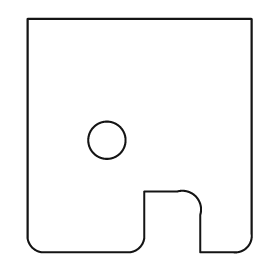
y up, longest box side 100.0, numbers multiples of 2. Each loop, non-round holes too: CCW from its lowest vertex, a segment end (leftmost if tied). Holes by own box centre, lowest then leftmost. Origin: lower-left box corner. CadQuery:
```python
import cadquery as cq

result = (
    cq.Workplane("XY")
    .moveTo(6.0, 0.0)
    .lineTo(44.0, 0.0)
    .threePointArc((48.0, 2.0), (50.0, 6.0))
    .lineTo(50.0, 26.0)
    .lineTo(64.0, 26.0)
    .threePointArc((72.0, 24.0), (74.0, 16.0))
    .lineTo(74.0, 0.0)
    .lineTo(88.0, 0.0)
    .threePointArc((94.0, 2.0), (96.0, 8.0))
    .lineTo(96.0, 100.0)
    .lineTo(0.0, 100.0)
    .lineTo(0.0, 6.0)
    .threePointArc((2.0, 2.0), (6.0, 0.0))
    .close()
    .moveTo(34.0, 48.0)
    .circle(8.0)
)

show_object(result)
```